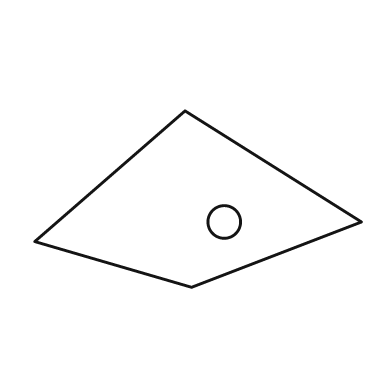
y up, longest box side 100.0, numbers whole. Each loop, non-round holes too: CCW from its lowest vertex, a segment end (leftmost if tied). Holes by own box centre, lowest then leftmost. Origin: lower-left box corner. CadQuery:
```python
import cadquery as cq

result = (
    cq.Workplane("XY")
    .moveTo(48.0, 0.0)
    .lineTo(100.0, 20.0)
    .lineTo(46.0, 54.0)
    .lineTo(0.0, 14.0)
    .close()
    .moveTo(58.0, 20.0)
    .circle(5.0)
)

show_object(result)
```